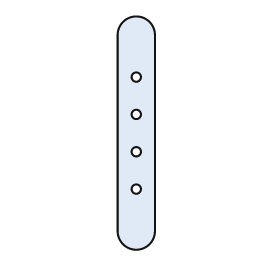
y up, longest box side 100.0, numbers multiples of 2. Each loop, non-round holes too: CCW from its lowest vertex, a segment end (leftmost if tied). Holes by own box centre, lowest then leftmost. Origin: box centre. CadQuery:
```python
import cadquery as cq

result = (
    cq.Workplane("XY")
    .moveTo(-8.0, -42.0)
    .threePointArc((0.0, -50.0), (8.0, -42.0))
    .lineTo(8.0, 42.0)
    .threePointArc((0.0, 50.0), (-8.0, 42.0))
    .close()
    .moveTo(0.0, -24.0)
    .circle(2.0)
    .moveTo(0.0, -8.0)
    .circle(2.0)
    .moveTo(0.0, 8.0)
    .circle(2.0)
    .moveTo(0.0, 24.0)
    .circle(2.0)
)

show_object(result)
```